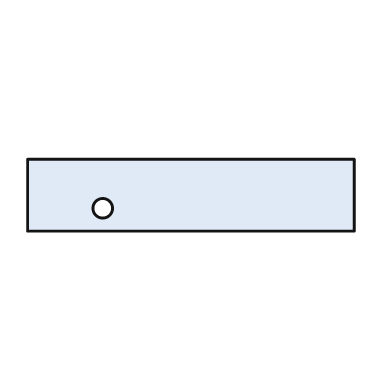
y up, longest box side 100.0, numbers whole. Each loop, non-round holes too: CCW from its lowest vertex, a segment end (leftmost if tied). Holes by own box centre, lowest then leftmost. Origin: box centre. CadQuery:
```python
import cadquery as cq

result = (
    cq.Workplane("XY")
    .moveTo(-50.0, -11.0)
    .lineTo(50.0, -11.0)
    .lineTo(50.0, 11.0)
    .lineTo(-50.0, 11.0)
    .close()
    .moveTo(-27.0, -4.0)
    .circle(3.0)
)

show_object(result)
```